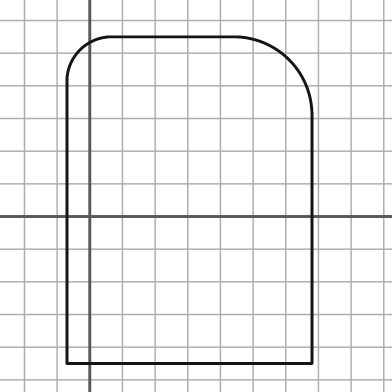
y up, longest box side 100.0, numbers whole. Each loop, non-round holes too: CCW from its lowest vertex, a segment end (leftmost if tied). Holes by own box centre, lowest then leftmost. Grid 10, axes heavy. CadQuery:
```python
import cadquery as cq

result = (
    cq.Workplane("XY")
    .moveTo(-7.0, -45.0)
    .lineTo(68.0, -45.0)
    .lineTo(68.0, 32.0)
    .threePointArc((61.0, 48.0), (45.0, 55.0))
    .lineTo(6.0, 55.0)
    .threePointArc((-3.0, 51.0), (-7.0, 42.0))
    .close()
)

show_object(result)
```